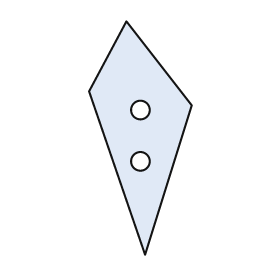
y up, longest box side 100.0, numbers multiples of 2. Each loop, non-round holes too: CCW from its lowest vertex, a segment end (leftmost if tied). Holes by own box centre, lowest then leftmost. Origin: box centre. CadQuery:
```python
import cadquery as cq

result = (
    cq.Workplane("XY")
    .moveTo(2.0, -50.0)
    .lineTo(22.0, 14.0)
    .lineTo(-6.0, 50.0)
    .lineTo(-22.0, 20.0)
    .close()
    .moveTo(0.0, -10.0)
    .circle(4.0)
    .moveTo(0.0, 12.0)
    .circle(4.0)
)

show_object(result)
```